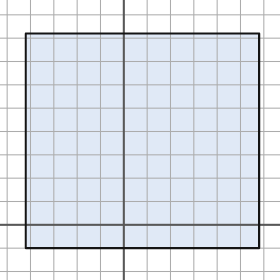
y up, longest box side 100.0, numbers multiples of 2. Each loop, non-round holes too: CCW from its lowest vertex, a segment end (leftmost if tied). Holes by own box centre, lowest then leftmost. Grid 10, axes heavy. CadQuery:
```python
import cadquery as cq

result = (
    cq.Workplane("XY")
    .moveTo(-42.0, -10.0)
    .lineTo(58.0, -10.0)
    .lineTo(58.0, 82.0)
    .lineTo(-42.0, 82.0)
    .close()
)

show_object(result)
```